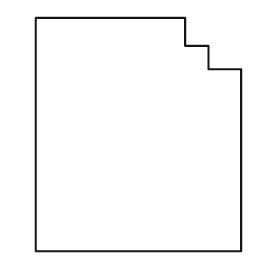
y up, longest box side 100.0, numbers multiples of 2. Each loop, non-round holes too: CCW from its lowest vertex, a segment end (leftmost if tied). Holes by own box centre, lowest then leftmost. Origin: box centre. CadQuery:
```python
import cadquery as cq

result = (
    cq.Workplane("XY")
    .moveTo(-44.0, -50.0)
    .lineTo(44.0, -50.0)
    .lineTo(44.0, 28.0)
    .lineTo(30.0, 28.0)
    .lineTo(30.0, 38.0)
    .lineTo(20.0, 38.0)
    .lineTo(20.0, 50.0)
    .lineTo(-44.0, 50.0)
    .close()
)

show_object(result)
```